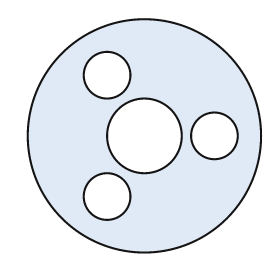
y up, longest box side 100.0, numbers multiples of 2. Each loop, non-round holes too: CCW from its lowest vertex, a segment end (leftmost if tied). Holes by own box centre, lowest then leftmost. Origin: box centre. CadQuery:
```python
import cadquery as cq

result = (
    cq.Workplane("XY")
    .moveTo(0.0, 0.0)
    .circle(50.0)
    .moveTo(-16.0, -26.0)
    .circle(10.0)
    .moveTo(0.0, 0.0)
    .circle(16.0)
    .moveTo(30.0, 0.0)
    .circle(10.0)
    .moveTo(-16.0, 26.0)
    .circle(10.0)
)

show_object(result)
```